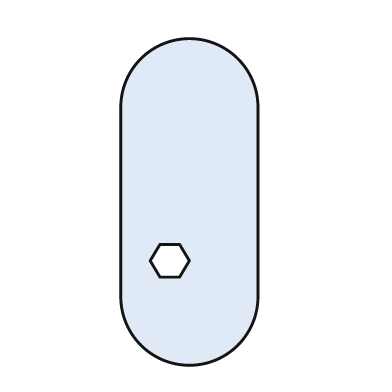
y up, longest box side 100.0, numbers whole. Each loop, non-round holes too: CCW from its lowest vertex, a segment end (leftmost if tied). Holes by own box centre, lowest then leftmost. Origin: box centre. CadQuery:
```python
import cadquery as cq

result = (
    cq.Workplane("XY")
    .moveTo(-21.0, -29.0)
    .threePointArc((0.0, -50.0), (21.0, -29.0))
    .lineTo(21.0, 29.0)
    .threePointArc((0.0, 50.0), (-21.0, 29.0))
    .close()
    .moveTo(-9.0, -23.0)
    .lineTo(-3.0, -23.0)
    .lineTo(0.0, -18.0)
    .lineTo(-3.0, -13.0)
    .lineTo(-9.0, -13.0)
    .lineTo(-12.0, -18.0)
    .close()
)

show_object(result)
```